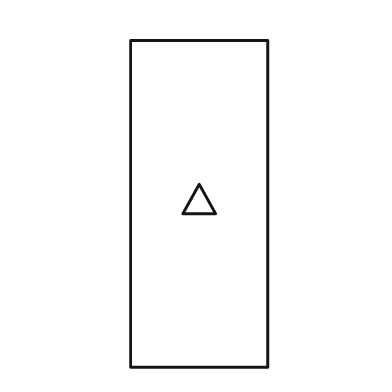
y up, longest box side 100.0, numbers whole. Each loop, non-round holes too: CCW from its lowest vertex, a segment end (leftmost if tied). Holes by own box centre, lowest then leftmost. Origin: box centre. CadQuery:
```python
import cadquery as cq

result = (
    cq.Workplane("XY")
    .moveTo(-21.0, -50.0)
    .lineTo(21.0, -50.0)
    .lineTo(21.0, 50.0)
    .lineTo(-21.0, 50.0)
    .close()
    .moveTo(-5.0, -3.0)
    .lineTo(5.0, -3.0)
    .lineTo(0.0, 6.0)
    .close()
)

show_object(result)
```